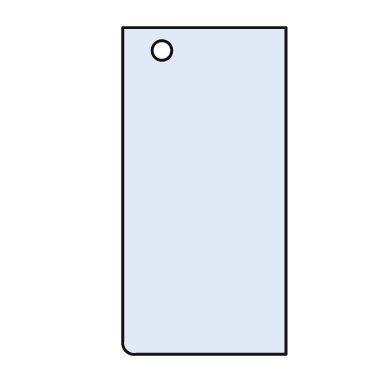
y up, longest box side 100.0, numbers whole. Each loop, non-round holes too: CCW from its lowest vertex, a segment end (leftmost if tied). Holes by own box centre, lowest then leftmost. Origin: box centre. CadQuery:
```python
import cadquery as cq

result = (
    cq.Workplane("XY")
    .moveTo(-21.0, -50.0)
    .lineTo(25.0, -50.0)
    .lineTo(25.0, 50.0)
    .lineTo(-25.0, 50.0)
    .lineTo(-25.0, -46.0)
    .threePointArc((-24.0, -49.0), (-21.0, -50.0))
    .close()
    .moveTo(-13.0, 43.0)
    .circle(3.0)
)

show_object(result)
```